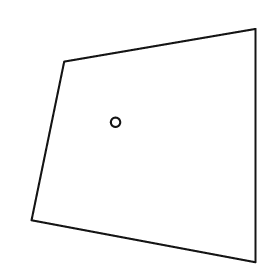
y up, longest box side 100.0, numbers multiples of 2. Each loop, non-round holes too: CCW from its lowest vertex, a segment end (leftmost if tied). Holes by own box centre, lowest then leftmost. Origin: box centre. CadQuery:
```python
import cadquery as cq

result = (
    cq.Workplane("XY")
    .moveTo(48.0, -50.0)
    .lineTo(48.0, 50.0)
    .lineTo(-34.0, 36.0)
    .lineTo(-48.0, -32.0)
    .close()
    .moveTo(-12.0, 10.0)
    .circle(2.0)
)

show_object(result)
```